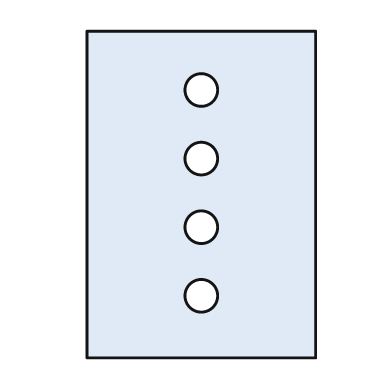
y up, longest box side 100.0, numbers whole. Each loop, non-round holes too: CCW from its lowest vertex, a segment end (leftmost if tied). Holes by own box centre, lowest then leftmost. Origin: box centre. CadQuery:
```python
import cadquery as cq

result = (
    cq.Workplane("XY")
    .moveTo(-35.0, -50.0)
    .lineTo(35.0, -50.0)
    .lineTo(35.0, 50.0)
    .lineTo(-35.0, 50.0)
    .close()
    .moveTo(0.0, -31.0)
    .circle(5.0)
    .moveTo(0.0, -10.0)
    .circle(5.0)
    .moveTo(0.0, 11.0)
    .circle(5.0)
    .moveTo(0.0, 32.0)
    .circle(5.0)
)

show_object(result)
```